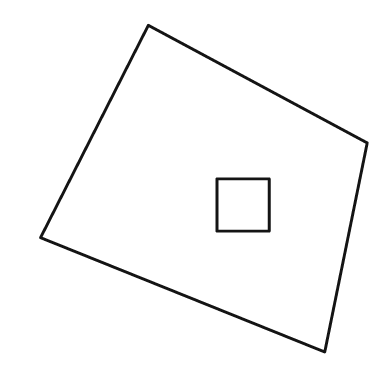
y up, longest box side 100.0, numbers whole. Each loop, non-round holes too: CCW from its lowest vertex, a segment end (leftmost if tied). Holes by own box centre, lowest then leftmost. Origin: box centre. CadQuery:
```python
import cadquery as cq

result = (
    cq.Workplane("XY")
    .moveTo(37.0, -50.0)
    .lineTo(50.0, 14.0)
    .lineTo(-17.0, 50.0)
    .lineTo(-50.0, -15.0)
    .close()
    .moveTo(4.0, -13.0)
    .lineTo(20.0, -13.0)
    .lineTo(20.0, 3.0)
    .lineTo(4.0, 3.0)
    .close()
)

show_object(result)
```